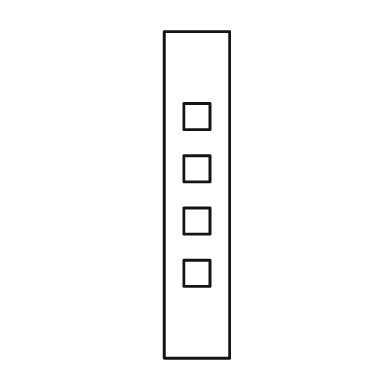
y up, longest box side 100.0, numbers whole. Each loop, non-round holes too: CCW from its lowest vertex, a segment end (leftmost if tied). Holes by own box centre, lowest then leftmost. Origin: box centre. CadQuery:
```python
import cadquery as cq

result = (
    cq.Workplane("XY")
    .moveTo(-10.0, -50.0)
    .lineTo(10.0, -50.0)
    .lineTo(10.0, 50.0)
    .lineTo(-10.0, 50.0)
    .close()
    .moveTo(-4.0, -28.0)
    .lineTo(4.0, -28.0)
    .lineTo(4.0, -20.0)
    .lineTo(-4.0, -20.0)
    .close()
    .moveTo(-4.0, -12.0)
    .lineTo(4.0, -12.0)
    .lineTo(4.0, -4.0)
    .lineTo(-4.0, -4.0)
    .close()
    .moveTo(-4.0, 4.0)
    .lineTo(4.0, 4.0)
    .lineTo(4.0, 12.0)
    .lineTo(-4.0, 12.0)
    .close()
    .moveTo(-4.0, 20.0)
    .lineTo(4.0, 20.0)
    .lineTo(4.0, 28.0)
    .lineTo(-4.0, 28.0)
    .close()
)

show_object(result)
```